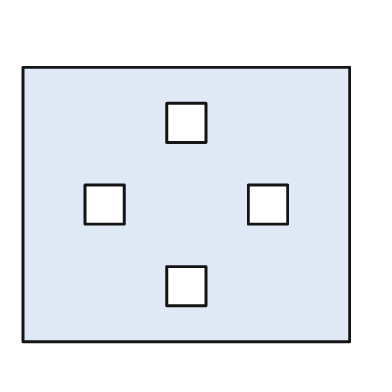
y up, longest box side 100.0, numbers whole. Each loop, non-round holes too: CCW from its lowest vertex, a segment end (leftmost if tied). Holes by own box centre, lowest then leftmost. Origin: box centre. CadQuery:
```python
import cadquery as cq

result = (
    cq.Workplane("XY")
    .moveTo(-50.0, -42.0)
    .lineTo(50.0, -42.0)
    .lineTo(50.0, 42.0)
    .lineTo(-50.0, 42.0)
    .close()
    .moveTo(-6.0, -31.0)
    .lineTo(6.0, -31.0)
    .lineTo(6.0, -19.0)
    .lineTo(-6.0, -19.0)
    .close()
    .moveTo(-31.0, -6.0)
    .lineTo(-19.0, -6.0)
    .lineTo(-19.0, 6.0)
    .lineTo(-31.0, 6.0)
    .close()
    .moveTo(19.0, -6.0)
    .lineTo(31.0, -6.0)
    .lineTo(31.0, 6.0)
    .lineTo(19.0, 6.0)
    .close()
    .moveTo(-6.0, 19.0)
    .lineTo(6.0, 19.0)
    .lineTo(6.0, 31.0)
    .lineTo(-6.0, 31.0)
    .close()
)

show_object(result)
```